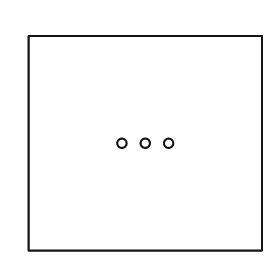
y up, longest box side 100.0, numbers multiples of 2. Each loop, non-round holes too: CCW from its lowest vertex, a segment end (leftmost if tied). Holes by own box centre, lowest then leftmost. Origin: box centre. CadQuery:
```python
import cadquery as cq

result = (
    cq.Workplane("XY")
    .moveTo(-50.0, -46.0)
    .lineTo(50.0, -46.0)
    .lineTo(50.0, 46.0)
    .lineTo(-50.0, 46.0)
    .close()
    .moveTo(-10.0, 0.0)
    .circle(2.0)
    .moveTo(0.0, 0.0)
    .circle(2.0)
    .moveTo(10.0, 0.0)
    .circle(2.0)
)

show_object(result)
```